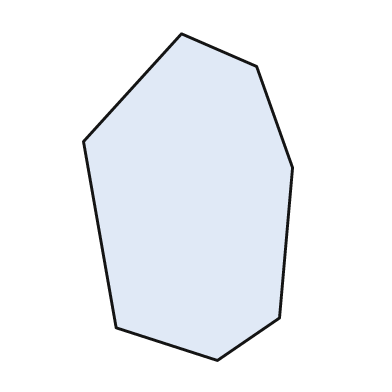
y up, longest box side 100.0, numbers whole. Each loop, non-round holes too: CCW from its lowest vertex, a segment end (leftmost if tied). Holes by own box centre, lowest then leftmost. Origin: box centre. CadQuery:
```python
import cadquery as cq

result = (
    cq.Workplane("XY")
    .moveTo(9.0, -50.0)
    .lineTo(28.0, -37.0)
    .lineTo(32.0, 9.0)
    .lineTo(21.0, 40.0)
    .lineTo(-2.0, 50.0)
    .lineTo(-32.0, 17.0)
    .lineTo(-22.0, -40.0)
    .close()
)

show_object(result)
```